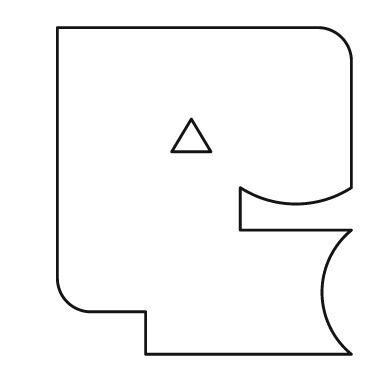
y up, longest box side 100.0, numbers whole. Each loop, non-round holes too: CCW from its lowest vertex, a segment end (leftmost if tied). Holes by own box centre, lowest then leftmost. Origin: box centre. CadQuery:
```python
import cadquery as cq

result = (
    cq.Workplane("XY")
    .moveTo(-18.0, -50.0)
    .lineTo(45.0, -50.0)
    .threePointArc((36.0, -31.0), (45.0, -12.0))
    .lineTo(11.0, -12.0)
    .lineTo(11.0, 1.0)
    .threePointArc((28.0, -4.0), (45.0, 1.0))
    .lineTo(45.0, 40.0)
    .threePointArc((42.0, 47.0), (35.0, 50.0))
    .lineTo(-45.0, 50.0)
    .lineTo(-45.0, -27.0)
    .threePointArc((-42.0, -34.0), (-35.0, -37.0))
    .lineTo(-18.0, -37.0)
    .close()
    .moveTo(-10.0, 12.0)
    .lineTo(2.0, 12.0)
    .lineTo(-4.0, 22.0)
    .close()
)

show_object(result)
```